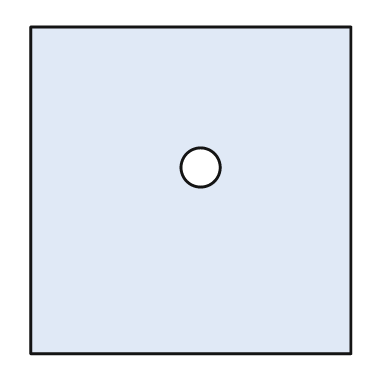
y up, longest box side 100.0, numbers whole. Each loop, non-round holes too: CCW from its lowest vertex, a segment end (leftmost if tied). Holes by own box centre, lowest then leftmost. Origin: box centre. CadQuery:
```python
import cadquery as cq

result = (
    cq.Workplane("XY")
    .moveTo(-49.0, -50.0)
    .lineTo(49.0, -50.0)
    .lineTo(49.0, 50.0)
    .lineTo(-49.0, 50.0)
    .close()
    .moveTo(3.0, 7.0)
    .circle(6.0)
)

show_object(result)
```